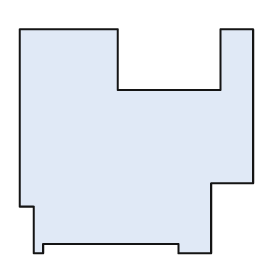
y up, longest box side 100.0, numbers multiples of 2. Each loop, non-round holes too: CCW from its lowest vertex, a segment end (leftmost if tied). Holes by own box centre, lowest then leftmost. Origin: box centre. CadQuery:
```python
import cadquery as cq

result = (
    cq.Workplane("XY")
    .moveTo(-44.0, -48.0)
    .lineTo(-40.0, -48.0)
    .lineTo(-40.0, -44.0)
    .lineTo(18.0, -44.0)
    .lineTo(18.0, -48.0)
    .lineTo(32.0, -48.0)
    .lineTo(32.0, -18.0)
    .lineTo(50.0, -18.0)
    .lineTo(50.0, 48.0)
    .lineTo(36.0, 48.0)
    .lineTo(36.0, 22.0)
    .lineTo(-8.0, 22.0)
    .lineTo(-8.0, 48.0)
    .lineTo(-50.0, 48.0)
    .lineTo(-50.0, -28.0)
    .lineTo(-44.0, -28.0)
    .close()
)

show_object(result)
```